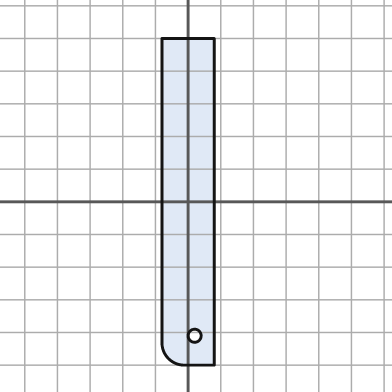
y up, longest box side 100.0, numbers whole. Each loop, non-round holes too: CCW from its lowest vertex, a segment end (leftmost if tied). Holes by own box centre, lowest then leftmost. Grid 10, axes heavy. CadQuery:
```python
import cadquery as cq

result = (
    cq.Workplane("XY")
    .moveTo(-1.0, -50.0)
    .lineTo(8.0, -50.0)
    .lineTo(8.0, 50.0)
    .lineTo(-8.0, 50.0)
    .lineTo(-8.0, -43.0)
    .threePointArc((-6.0, -48.0), (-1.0, -50.0))
    .close()
    .moveTo(2.0, -41.0)
    .circle(2.0)
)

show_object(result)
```